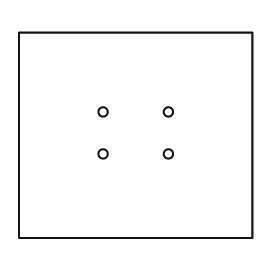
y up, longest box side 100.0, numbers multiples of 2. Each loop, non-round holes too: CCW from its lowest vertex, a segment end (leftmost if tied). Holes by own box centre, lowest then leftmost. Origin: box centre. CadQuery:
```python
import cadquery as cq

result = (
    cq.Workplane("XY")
    .moveTo(-50.0, -44.0)
    .lineTo(50.0, -44.0)
    .lineTo(50.0, 44.0)
    .lineTo(-50.0, 44.0)
    .close()
    .moveTo(-14.0, -8.0)
    .circle(2.0)
    .moveTo(14.0, -8.0)
    .circle(2.0)
    .moveTo(-14.0, 10.0)
    .circle(2.0)
    .moveTo(14.0, 10.0)
    .circle(2.0)
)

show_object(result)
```